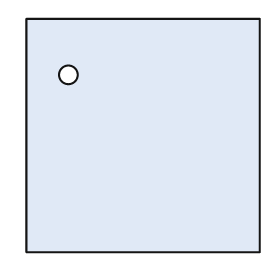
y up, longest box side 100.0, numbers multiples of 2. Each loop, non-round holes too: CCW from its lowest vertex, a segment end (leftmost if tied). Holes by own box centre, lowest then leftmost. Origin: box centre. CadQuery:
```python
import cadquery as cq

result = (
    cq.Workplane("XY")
    .moveTo(-50.0, -50.0)
    .lineTo(50.0, -50.0)
    .lineTo(50.0, 50.0)
    .lineTo(-50.0, 50.0)
    .close()
    .moveTo(-32.0, 26.0)
    .circle(4.0)
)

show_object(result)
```